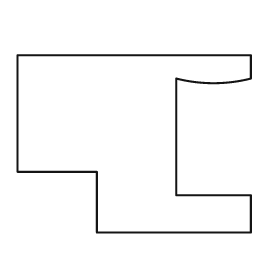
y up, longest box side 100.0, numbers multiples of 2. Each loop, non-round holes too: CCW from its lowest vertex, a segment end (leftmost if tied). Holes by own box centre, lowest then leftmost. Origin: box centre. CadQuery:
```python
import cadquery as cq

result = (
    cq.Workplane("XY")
    .moveTo(-16.0, -38.0)
    .lineTo(50.0, -38.0)
    .lineTo(50.0, -22.0)
    .lineTo(18.0, -22.0)
    .lineTo(18.0, 28.0)
    .threePointArc((34.0, 26.0), (50.0, 28.0))
    .lineTo(50.0, 38.0)
    .lineTo(-50.0, 38.0)
    .lineTo(-50.0, -12.0)
    .lineTo(-16.0, -12.0)
    .close()
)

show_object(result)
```